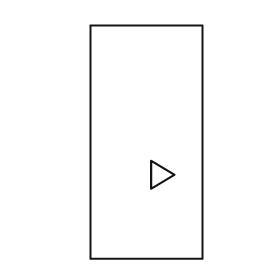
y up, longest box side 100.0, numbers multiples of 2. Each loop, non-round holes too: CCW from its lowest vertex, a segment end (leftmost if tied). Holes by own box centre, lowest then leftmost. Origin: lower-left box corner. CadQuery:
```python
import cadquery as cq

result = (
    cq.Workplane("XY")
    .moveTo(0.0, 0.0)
    .lineTo(48.0, 0.0)
    .lineTo(48.0, 100.0)
    .lineTo(0.0, 100.0)
    .close()
    .moveTo(26.0, 30.0)
    .lineTo(36.0, 36.0)
    .lineTo(26.0, 42.0)
    .close()
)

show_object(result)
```